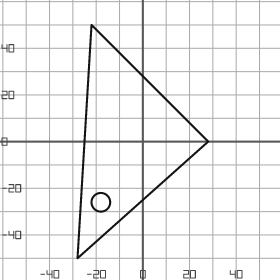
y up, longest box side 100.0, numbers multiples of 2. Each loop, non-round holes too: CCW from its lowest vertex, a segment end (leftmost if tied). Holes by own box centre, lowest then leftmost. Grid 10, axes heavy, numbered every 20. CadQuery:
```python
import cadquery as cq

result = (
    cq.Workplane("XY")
    .moveTo(-28.0, -50.0)
    .lineTo(28.0, 0.0)
    .lineTo(-22.0, 50.0)
    .close()
    .moveTo(-18.0, -26.0)
    .circle(4.0)
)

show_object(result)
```